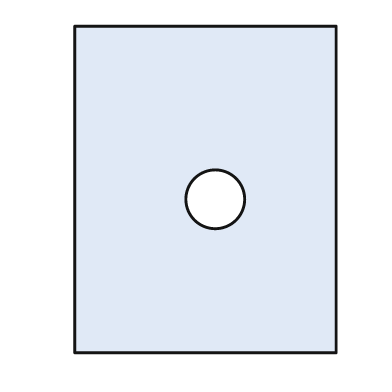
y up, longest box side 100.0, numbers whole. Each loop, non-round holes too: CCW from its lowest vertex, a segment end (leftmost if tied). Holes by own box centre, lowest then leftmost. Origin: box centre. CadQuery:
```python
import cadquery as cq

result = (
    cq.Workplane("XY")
    .moveTo(-40.0, -50.0)
    .lineTo(40.0, -50.0)
    .lineTo(40.0, 50.0)
    .lineTo(-40.0, 50.0)
    .close()
    .moveTo(3.0, -3.0)
    .circle(9.0)
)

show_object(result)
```